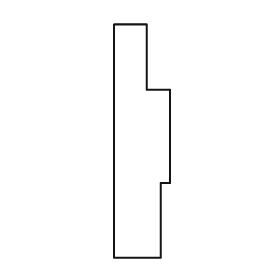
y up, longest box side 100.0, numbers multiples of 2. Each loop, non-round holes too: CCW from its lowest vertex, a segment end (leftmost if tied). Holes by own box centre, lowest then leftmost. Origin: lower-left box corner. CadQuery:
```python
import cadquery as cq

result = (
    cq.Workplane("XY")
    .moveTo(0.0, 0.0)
    .lineTo(20.0, 0.0)
    .lineTo(20.0, 32.0)
    .lineTo(24.0, 32.0)
    .lineTo(24.0, 72.0)
    .lineTo(14.0, 72.0)
    .lineTo(14.0, 100.0)
    .lineTo(0.0, 100.0)
    .close()
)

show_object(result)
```